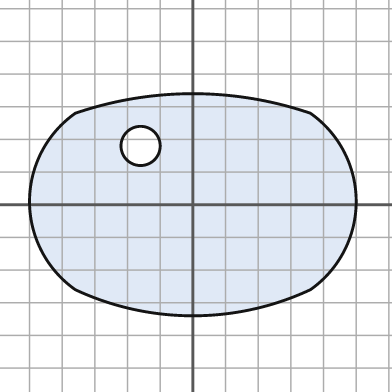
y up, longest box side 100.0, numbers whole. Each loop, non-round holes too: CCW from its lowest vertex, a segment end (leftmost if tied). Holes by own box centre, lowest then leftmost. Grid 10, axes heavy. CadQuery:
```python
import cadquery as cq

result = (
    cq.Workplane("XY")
    .moveTo(-36.0, -26.0)
    .threePointArc((0.0, -34.0), (36.0, -26.0))
    .threePointArc((50.0, 1.0), (36.0, 28.0))
    .threePointArc((0.0, 34.0), (-36.0, 28.0))
    .threePointArc((-50.0, 1.0), (-36.0, -26.0))
    .close()
    .moveTo(-16.0, 18.0)
    .circle(6.0)
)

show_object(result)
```